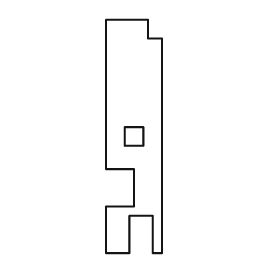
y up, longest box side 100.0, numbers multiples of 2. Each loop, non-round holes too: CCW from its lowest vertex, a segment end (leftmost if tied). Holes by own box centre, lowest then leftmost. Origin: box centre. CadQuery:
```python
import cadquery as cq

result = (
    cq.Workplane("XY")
    .moveTo(-12.0, -50.0)
    .lineTo(-2.0, -50.0)
    .lineTo(-2.0, -34.0)
    .lineTo(8.0, -34.0)
    .lineTo(8.0, -50.0)
    .lineTo(12.0, -50.0)
    .lineTo(12.0, 42.0)
    .lineTo(6.0, 42.0)
    .lineTo(6.0, 50.0)
    .lineTo(-12.0, 50.0)
    .lineTo(-12.0, -14.0)
    .lineTo(0.0, -14.0)
    .lineTo(0.0, -30.0)
    .lineTo(-12.0, -30.0)
    .close()
    .moveTo(-4.0, -4.0)
    .lineTo(4.0, -4.0)
    .lineTo(4.0, 4.0)
    .lineTo(-4.0, 4.0)
    .close()
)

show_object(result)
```